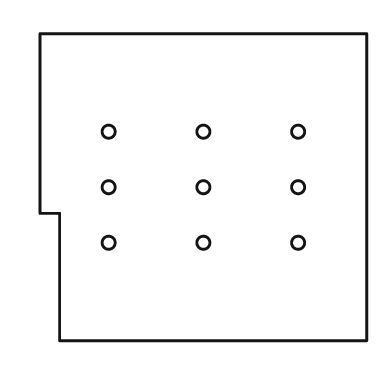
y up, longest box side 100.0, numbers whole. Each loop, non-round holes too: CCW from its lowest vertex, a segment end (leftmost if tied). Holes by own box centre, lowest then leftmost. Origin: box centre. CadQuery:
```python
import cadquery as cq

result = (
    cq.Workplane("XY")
    .moveTo(-44.0, -47.0)
    .lineTo(50.0, -47.0)
    .lineTo(50.0, 47.0)
    .lineTo(-50.0, 47.0)
    .lineTo(-50.0, -8.0)
    .lineTo(-44.0, -8.0)
    .close()
    .moveTo(-29.0, -17.0)
    .circle(2.0)
    .moveTo(0.0, -17.0)
    .circle(2.0)
    .moveTo(29.0, -17.0)
    .circle(2.0)
    .moveTo(-29.0, 0.0)
    .circle(2.0)
    .moveTo(0.0, 0.0)
    .circle(2.0)
    .moveTo(29.0, 0.0)
    .circle(2.0)
    .moveTo(-29.0, 17.0)
    .circle(2.0)
    .moveTo(0.0, 17.0)
    .circle(2.0)
    .moveTo(29.0, 17.0)
    .circle(2.0)
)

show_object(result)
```